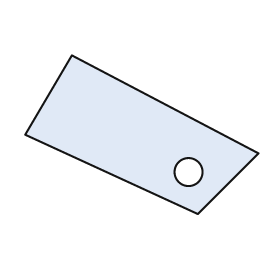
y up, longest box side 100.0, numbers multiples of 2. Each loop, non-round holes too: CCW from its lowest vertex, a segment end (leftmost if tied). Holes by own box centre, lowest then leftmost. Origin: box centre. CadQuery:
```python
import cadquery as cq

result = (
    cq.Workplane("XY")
    .moveTo(24.0, -34.0)
    .lineTo(50.0, -8.0)
    .lineTo(-30.0, 34.0)
    .lineTo(-50.0, 0.0)
    .close()
    .moveTo(20.0, -16.0)
    .circle(6.0)
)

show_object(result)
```